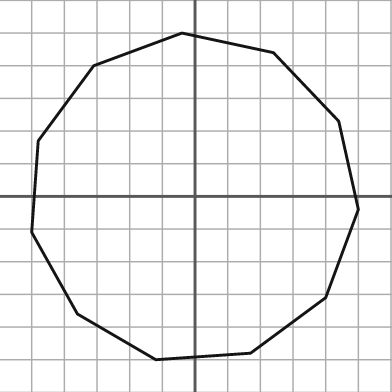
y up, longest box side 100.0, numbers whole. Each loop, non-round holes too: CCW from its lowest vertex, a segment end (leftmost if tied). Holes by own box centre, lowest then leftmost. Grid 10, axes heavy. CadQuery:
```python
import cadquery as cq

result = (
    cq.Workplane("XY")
    .moveTo(-12.0, -50.0)
    .lineTo(17.0, -48.0)
    .lineTo(40.0, -31.0)
    .lineTo(50.0, -4.0)
    .lineTo(44.0, 23.0)
    .lineTo(24.0, 44.0)
    .lineTo(-4.0, 50.0)
    .lineTo(-31.0, 40.0)
    .lineTo(-48.0, 17.0)
    .lineTo(-50.0, -11.0)
    .lineTo(-36.0, -36.0)
    .close()
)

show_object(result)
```